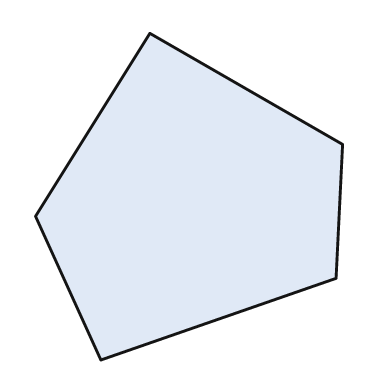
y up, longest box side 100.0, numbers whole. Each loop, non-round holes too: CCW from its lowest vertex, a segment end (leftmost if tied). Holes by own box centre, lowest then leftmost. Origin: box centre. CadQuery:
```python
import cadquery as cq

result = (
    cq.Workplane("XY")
    .moveTo(-27.0, -50.0)
    .lineTo(45.0, -25.0)
    .lineTo(47.0, 16.0)
    .lineTo(-12.0, 50.0)
    .lineTo(-47.0, -6.0)
    .close()
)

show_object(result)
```